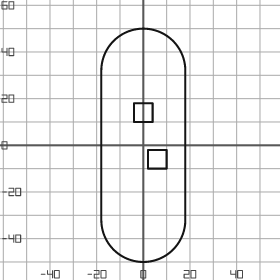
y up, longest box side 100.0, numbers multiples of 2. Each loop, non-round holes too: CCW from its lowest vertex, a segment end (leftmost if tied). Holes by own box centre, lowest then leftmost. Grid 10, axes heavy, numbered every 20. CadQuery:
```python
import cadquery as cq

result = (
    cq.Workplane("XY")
    .moveTo(-18.0, -32.0)
    .threePointArc((0.0, -50.0), (18.0, -32.0))
    .lineTo(18.0, 32.0)
    .threePointArc((0.0, 50.0), (-18.0, 32.0))
    .close()
    .moveTo(2.0, -10.0)
    .lineTo(10.0, -10.0)
    .lineTo(10.0, -2.0)
    .lineTo(2.0, -2.0)
    .close()
    .moveTo(-4.0, 10.0)
    .lineTo(4.0, 10.0)
    .lineTo(4.0, 18.0)
    .lineTo(-4.0, 18.0)
    .close()
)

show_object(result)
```